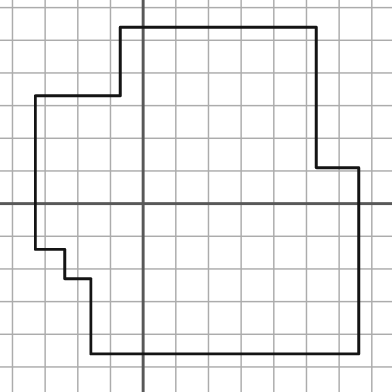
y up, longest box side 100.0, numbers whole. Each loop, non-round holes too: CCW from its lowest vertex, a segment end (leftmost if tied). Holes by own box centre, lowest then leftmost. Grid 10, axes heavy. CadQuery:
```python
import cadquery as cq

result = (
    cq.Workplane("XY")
    .moveTo(-16.0, -46.0)
    .lineTo(66.0, -46.0)
    .lineTo(66.0, 11.0)
    .lineTo(53.0, 11.0)
    .lineTo(53.0, 54.0)
    .lineTo(-7.0, 54.0)
    .lineTo(-7.0, 33.0)
    .lineTo(-33.0, 33.0)
    .lineTo(-33.0, -14.0)
    .lineTo(-24.0, -14.0)
    .lineTo(-24.0, -23.0)
    .lineTo(-16.0, -23.0)
    .close()
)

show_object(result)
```